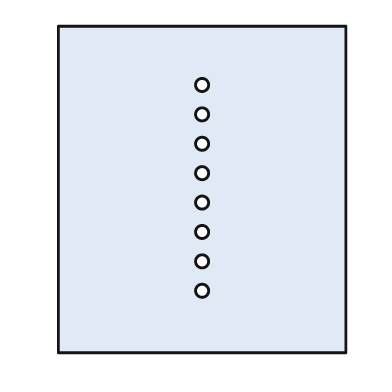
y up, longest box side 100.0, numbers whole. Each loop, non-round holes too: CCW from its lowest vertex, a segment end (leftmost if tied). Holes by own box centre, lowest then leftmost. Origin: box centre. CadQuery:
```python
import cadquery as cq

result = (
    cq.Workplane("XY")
    .moveTo(-44.0, -50.0)
    .lineTo(44.0, -50.0)
    .lineTo(44.0, 50.0)
    .lineTo(-44.0, 50.0)
    .close()
    .moveTo(0.0, -31.0)
    .circle(2.0)
    .moveTo(0.0, -22.0)
    .circle(2.0)
    .moveTo(0.0, -13.0)
    .circle(2.0)
    .moveTo(0.0, -4.0)
    .circle(2.0)
    .moveTo(0.0, 5.0)
    .circle(2.0)
    .moveTo(0.0, 14.0)
    .circle(2.0)
    .moveTo(0.0, 23.0)
    .circle(2.0)
    .moveTo(0.0, 32.0)
    .circle(2.0)
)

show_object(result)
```